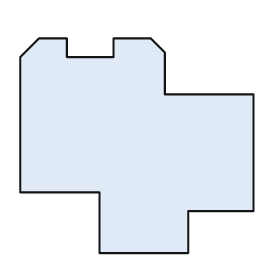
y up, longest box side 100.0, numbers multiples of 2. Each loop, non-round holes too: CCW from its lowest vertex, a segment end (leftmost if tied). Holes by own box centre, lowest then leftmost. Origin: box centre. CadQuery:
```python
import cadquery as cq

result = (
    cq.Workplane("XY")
    .moveTo(-16.0, -46.0)
    .lineTo(22.0, -46.0)
    .lineTo(22.0, -28.0)
    .lineTo(50.0, -28.0)
    .lineTo(50.0, 22.0)
    .lineTo(12.0, 22.0)
    .lineTo(12.0, 40.0)
    .lineTo(6.0, 46.0)
    .lineTo(-10.0, 46.0)
    .lineTo(-10.0, 38.0)
    .lineTo(-30.0, 38.0)
    .lineTo(-30.0, 46.0)
    .lineTo(-42.0, 46.0)
    .lineTo(-50.0, 38.0)
    .lineTo(-50.0, -20.0)
    .lineTo(-16.0, -20.0)
    .close()
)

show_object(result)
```